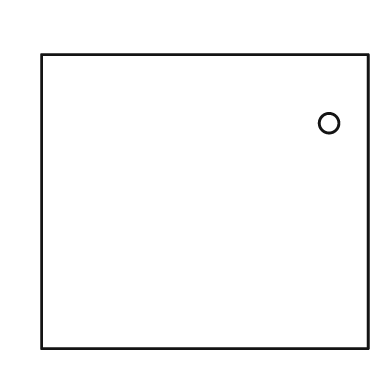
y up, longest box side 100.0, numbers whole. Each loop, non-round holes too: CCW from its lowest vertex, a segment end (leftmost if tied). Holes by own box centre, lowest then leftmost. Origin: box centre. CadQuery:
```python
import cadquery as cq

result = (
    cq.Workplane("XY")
    .moveTo(-50.0, -45.0)
    .lineTo(50.0, -45.0)
    .lineTo(50.0, 45.0)
    .lineTo(-50.0, 45.0)
    .close()
    .moveTo(38.0, 24.0)
    .circle(3.0)
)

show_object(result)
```